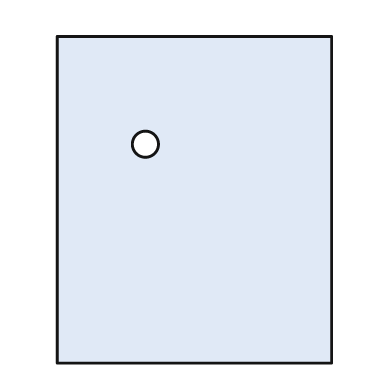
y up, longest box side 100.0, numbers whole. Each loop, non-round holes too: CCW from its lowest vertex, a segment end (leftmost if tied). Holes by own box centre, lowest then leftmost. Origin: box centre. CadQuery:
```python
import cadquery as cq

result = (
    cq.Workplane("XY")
    .moveTo(-42.0, -50.0)
    .lineTo(42.0, -50.0)
    .lineTo(42.0, 50.0)
    .lineTo(-42.0, 50.0)
    .close()
    .moveTo(-15.0, 17.0)
    .circle(4.0)
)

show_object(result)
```